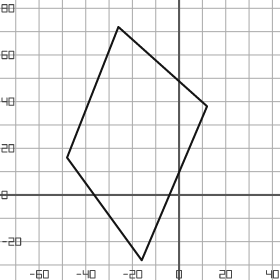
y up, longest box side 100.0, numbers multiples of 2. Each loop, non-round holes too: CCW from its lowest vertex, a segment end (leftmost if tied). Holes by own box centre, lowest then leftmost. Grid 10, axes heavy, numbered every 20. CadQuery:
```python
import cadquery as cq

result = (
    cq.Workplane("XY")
    .moveTo(-16.0, -28.0)
    .lineTo(12.0, 38.0)
    .lineTo(-26.0, 72.0)
    .lineTo(-48.0, 16.0)
    .close()
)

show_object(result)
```